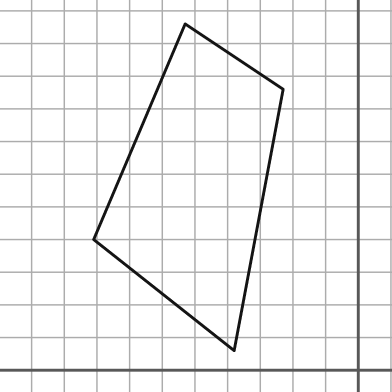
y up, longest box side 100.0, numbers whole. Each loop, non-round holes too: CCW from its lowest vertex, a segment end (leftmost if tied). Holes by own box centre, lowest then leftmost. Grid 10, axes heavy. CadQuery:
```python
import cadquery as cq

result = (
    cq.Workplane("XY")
    .moveTo(-38.0, 6.0)
    .lineTo(-23.0, 86.0)
    .lineTo(-53.0, 106.0)
    .lineTo(-81.0, 40.0)
    .close()
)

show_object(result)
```